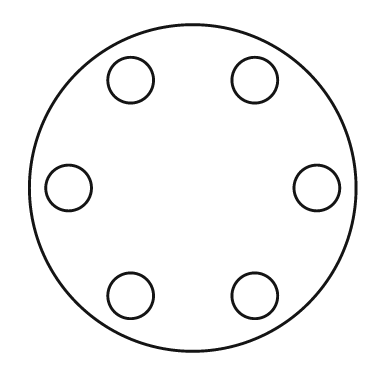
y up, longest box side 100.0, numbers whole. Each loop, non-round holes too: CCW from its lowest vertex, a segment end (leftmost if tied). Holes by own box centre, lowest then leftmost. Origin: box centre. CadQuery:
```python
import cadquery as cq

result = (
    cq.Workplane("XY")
    .moveTo(0.0, 0.0)
    .circle(50.0)
    .moveTo(-19.0, -33.0)
    .circle(7.0)
    .moveTo(19.0, -33.0)
    .circle(7.0)
    .moveTo(-38.0, 0.0)
    .circle(7.0)
    .moveTo(38.0, 0.0)
    .circle(7.0)
    .moveTo(-19.0, 33.0)
    .circle(7.0)
    .moveTo(19.0, 33.0)
    .circle(7.0)
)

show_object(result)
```